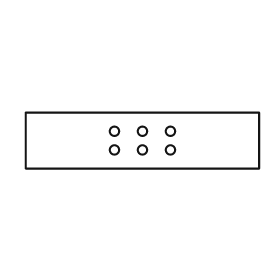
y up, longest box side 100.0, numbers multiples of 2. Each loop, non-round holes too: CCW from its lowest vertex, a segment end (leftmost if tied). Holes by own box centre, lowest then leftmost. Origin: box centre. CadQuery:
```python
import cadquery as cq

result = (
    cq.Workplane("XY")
    .moveTo(-50.0, -12.0)
    .lineTo(50.0, -12.0)
    .lineTo(50.0, 12.0)
    .lineTo(-50.0, 12.0)
    .close()
    .moveTo(-12.0, -4.0)
    .circle(2.0)
    .moveTo(0.0, -4.0)
    .circle(2.0)
    .moveTo(12.0, -4.0)
    .circle(2.0)
    .moveTo(-12.0, 4.0)
    .circle(2.0)
    .moveTo(0.0, 4.0)
    .circle(2.0)
    .moveTo(12.0, 4.0)
    .circle(2.0)
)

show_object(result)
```